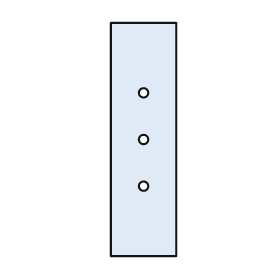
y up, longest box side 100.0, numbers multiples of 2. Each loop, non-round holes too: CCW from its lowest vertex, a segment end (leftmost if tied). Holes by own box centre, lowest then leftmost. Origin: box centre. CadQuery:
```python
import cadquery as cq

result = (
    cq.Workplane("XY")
    .moveTo(-14.0, -50.0)
    .lineTo(14.0, -50.0)
    .lineTo(14.0, 50.0)
    .lineTo(-14.0, 50.0)
    .close()
    .moveTo(0.0, -20.0)
    .circle(2.0)
    .moveTo(0.0, 0.0)
    .circle(2.0)
    .moveTo(0.0, 20.0)
    .circle(2.0)
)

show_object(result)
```